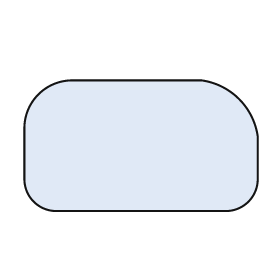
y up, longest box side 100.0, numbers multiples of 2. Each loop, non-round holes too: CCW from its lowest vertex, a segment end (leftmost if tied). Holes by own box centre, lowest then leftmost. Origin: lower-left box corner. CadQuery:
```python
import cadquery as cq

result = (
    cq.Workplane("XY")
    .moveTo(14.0, 0.0)
    .lineTo(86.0, 0.0)
    .threePointArc((96.0, 4.0), (100.0, 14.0))
    .lineTo(100.0, 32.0)
    .threePointArc((92.0, 48.0), (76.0, 56.0))
    .lineTo(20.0, 56.0)
    .threePointArc((6.0, 50.0), (0.0, 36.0))
    .lineTo(0.0, 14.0)
    .threePointArc((4.0, 4.0), (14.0, 0.0))
    .close()
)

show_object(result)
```